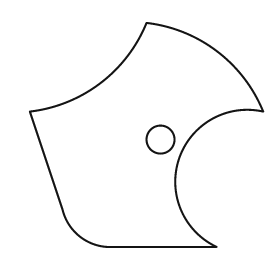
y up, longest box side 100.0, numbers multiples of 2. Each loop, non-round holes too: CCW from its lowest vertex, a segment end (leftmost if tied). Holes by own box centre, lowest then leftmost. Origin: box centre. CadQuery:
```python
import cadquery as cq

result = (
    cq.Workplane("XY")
    .moveTo(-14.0, -48.0)
    .lineTo(30.0, -48.0)
    .threePointArc((14.0, -10.0), (50.0, 10.0))
    .threePointArc((30.0, 36.0), (0.0, 48.0))
    .threePointArc((-20.0, 22.0), (-50.0, 10.0))
    .lineTo(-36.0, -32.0)
    .threePointArc((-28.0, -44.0), (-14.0, -48.0))
    .close()
    .moveTo(6.0, -2.0)
    .circle(6.0)
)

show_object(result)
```